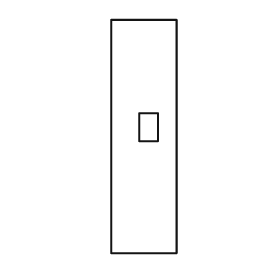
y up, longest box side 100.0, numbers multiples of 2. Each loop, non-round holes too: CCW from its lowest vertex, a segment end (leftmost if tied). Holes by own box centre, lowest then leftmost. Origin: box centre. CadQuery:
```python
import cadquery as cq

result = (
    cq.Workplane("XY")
    .moveTo(-14.0, -50.0)
    .lineTo(14.0, -50.0)
    .lineTo(14.0, 50.0)
    .lineTo(-14.0, 50.0)
    .close()
    .moveTo(-2.0, -2.0)
    .lineTo(6.0, -2.0)
    .lineTo(6.0, 10.0)
    .lineTo(-2.0, 10.0)
    .close()
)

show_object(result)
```